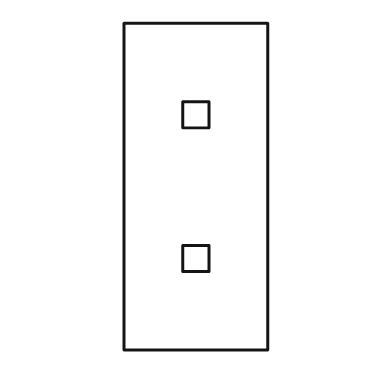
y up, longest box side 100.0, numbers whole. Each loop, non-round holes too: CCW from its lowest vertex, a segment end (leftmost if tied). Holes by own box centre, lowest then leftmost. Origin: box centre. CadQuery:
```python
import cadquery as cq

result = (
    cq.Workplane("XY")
    .moveTo(-22.0, -50.0)
    .lineTo(22.0, -50.0)
    .lineTo(22.0, 50.0)
    .lineTo(-22.0, 50.0)
    .close()
    .moveTo(-4.0, -26.0)
    .lineTo(4.0, -26.0)
    .lineTo(4.0, -18.0)
    .lineTo(-4.0, -18.0)
    .close()
    .moveTo(-4.0, 18.0)
    .lineTo(4.0, 18.0)
    .lineTo(4.0, 26.0)
    .lineTo(-4.0, 26.0)
    .close()
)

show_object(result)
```